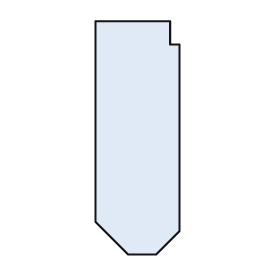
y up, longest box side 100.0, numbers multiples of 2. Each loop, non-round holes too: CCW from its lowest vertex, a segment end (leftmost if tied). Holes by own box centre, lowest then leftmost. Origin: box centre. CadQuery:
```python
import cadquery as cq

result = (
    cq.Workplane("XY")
    .moveTo(-4.0, -50.0)
    .lineTo(8.0, -50.0)
    .lineTo(18.0, -40.0)
    .lineTo(18.0, 40.0)
    .lineTo(14.0, 40.0)
    .lineTo(14.0, 50.0)
    .lineTo(-18.0, 50.0)
    .lineTo(-18.0, -36.0)
    .close()
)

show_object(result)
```